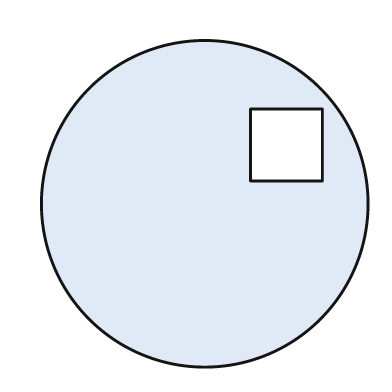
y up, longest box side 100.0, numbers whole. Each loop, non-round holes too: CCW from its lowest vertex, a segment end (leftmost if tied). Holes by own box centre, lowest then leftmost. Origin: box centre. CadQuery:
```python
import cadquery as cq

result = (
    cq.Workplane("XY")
    .moveTo(0.0, 0.0)
    .circle(50.0)
    .moveTo(14.0, 7.0)
    .lineTo(36.0, 7.0)
    .lineTo(36.0, 29.0)
    .lineTo(14.0, 29.0)
    .close()
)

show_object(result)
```